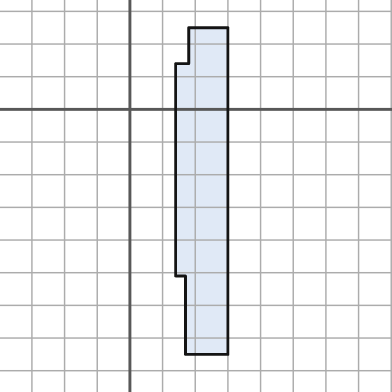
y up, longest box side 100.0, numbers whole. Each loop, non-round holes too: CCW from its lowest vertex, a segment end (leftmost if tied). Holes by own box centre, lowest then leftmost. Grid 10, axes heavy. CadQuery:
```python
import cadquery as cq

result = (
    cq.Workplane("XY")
    .moveTo(17.0, -75.0)
    .lineTo(30.0, -75.0)
    .lineTo(30.0, 25.0)
    .lineTo(18.0, 25.0)
    .lineTo(18.0, 14.0)
    .lineTo(14.0, 14.0)
    .lineTo(14.0, -51.0)
    .lineTo(17.0, -51.0)
    .close()
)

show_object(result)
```